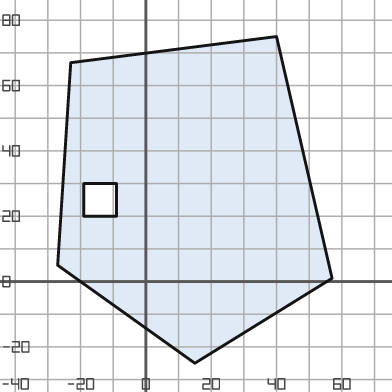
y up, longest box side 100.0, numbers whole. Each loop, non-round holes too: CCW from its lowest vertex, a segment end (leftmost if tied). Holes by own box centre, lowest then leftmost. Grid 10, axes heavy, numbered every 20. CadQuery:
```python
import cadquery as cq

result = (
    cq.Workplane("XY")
    .moveTo(15.0, -25.0)
    .lineTo(57.0, 1.0)
    .lineTo(40.0, 75.0)
    .lineTo(-23.0, 67.0)
    .lineTo(-27.0, 5.0)
    .close()
    .moveTo(-19.0, 20.0)
    .lineTo(-9.0, 20.0)
    .lineTo(-9.0, 30.0)
    .lineTo(-19.0, 30.0)
    .close()
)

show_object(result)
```